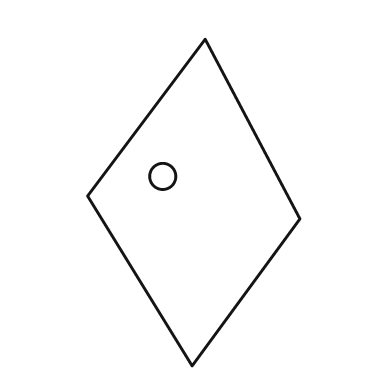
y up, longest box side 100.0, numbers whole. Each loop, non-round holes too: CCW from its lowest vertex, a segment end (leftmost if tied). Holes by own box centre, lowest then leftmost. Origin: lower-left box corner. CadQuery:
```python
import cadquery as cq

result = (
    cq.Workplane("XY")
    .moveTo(32.0, 0.0)
    .lineTo(65.0, 45.0)
    .lineTo(36.0, 100.0)
    .lineTo(0.0, 52.0)
    .close()
    .moveTo(23.0, 58.0)
    .circle(4.0)
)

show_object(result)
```